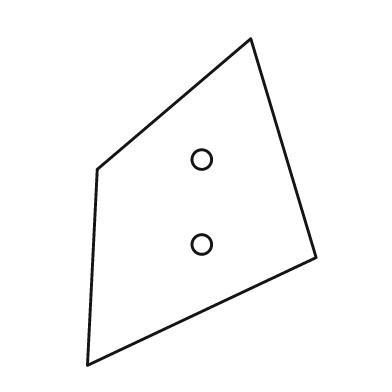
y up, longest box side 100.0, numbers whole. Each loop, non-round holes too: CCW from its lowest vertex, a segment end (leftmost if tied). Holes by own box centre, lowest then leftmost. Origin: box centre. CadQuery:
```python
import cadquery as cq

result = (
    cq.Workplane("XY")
    .moveTo(-35.0, -50.0)
    .lineTo(35.0, -17.0)
    .lineTo(15.0, 50.0)
    .lineTo(-32.0, 10.0)
    .close()
    .moveTo(0.0, -13.0)
    .circle(3.0)
    .moveTo(0.0, 13.0)
    .circle(3.0)
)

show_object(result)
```